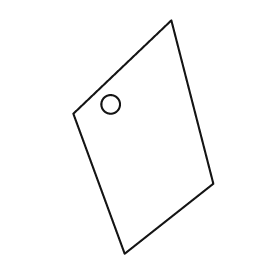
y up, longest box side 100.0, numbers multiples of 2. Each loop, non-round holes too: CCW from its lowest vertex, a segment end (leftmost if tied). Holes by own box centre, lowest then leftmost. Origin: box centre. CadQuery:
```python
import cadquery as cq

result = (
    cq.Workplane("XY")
    .moveTo(-8.0, -50.0)
    .lineTo(30.0, -20.0)
    .lineTo(12.0, 50.0)
    .lineTo(-30.0, 10.0)
    .close()
    .moveTo(-14.0, 14.0)
    .circle(4.0)
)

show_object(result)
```